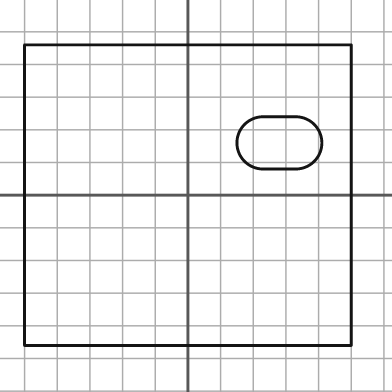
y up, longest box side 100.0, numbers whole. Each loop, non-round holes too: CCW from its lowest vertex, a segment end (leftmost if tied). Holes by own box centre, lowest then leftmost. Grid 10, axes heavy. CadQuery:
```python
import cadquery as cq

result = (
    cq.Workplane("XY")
    .moveTo(-50.0, -46.0)
    .lineTo(50.0, -46.0)
    .lineTo(50.0, 46.0)
    .lineTo(-50.0, 46.0)
    .close()
    .moveTo(23.0, 8.0)
    .lineTo(33.0, 8.0)
    .threePointArc((41.0, 16.0), (33.0, 24.0))
    .lineTo(23.0, 24.0)
    .threePointArc((15.0, 16.0), (23.0, 8.0))
    .close()
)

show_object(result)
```